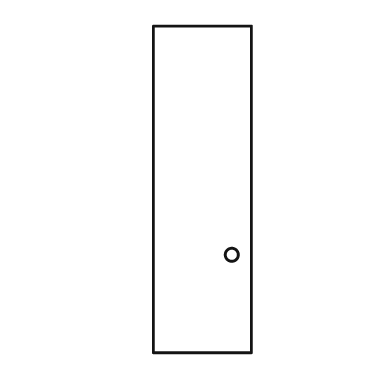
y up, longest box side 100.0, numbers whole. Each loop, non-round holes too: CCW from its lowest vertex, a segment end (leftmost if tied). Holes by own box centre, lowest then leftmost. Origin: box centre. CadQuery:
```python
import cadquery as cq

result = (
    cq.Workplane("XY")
    .moveTo(-15.0, -50.0)
    .lineTo(15.0, -50.0)
    .lineTo(15.0, 50.0)
    .lineTo(-15.0, 50.0)
    .close()
    .moveTo(9.0, -20.0)
    .circle(2.0)
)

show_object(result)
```